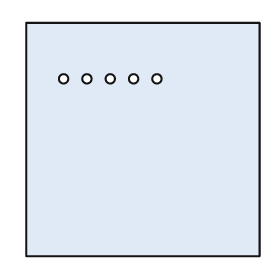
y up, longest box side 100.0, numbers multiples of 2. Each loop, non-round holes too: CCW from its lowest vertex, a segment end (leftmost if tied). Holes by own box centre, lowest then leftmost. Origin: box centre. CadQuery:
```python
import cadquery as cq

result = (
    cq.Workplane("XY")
    .moveTo(-50.0, -50.0)
    .lineTo(50.0, -50.0)
    .lineTo(50.0, 50.0)
    .lineTo(-50.0, 50.0)
    .close()
    .moveTo(-34.0, 26.0)
    .circle(2.0)
    .moveTo(-24.0, 26.0)
    .circle(2.0)
    .moveTo(-14.0, 26.0)
    .circle(2.0)
    .moveTo(-4.0, 26.0)
    .circle(2.0)
    .moveTo(6.0, 26.0)
    .circle(2.0)
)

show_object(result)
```